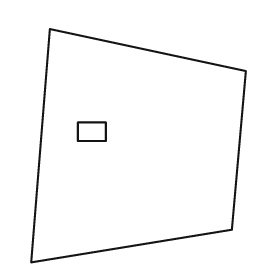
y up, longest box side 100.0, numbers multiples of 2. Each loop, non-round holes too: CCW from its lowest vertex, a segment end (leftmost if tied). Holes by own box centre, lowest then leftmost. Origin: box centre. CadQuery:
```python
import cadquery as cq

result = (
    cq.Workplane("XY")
    .moveTo(-46.0, -50.0)
    .lineTo(40.0, -36.0)
    .lineTo(46.0, 32.0)
    .lineTo(-38.0, 50.0)
    .close()
    .moveTo(-26.0, 2.0)
    .lineTo(-14.0, 2.0)
    .lineTo(-14.0, 10.0)
    .lineTo(-26.0, 10.0)
    .close()
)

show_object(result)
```